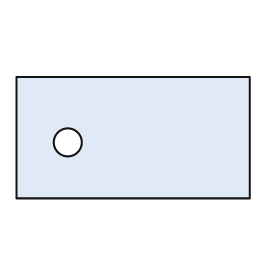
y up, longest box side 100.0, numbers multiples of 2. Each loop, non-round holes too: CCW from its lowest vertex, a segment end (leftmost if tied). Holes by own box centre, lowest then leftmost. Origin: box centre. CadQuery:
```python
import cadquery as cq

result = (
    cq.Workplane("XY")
    .moveTo(-50.0, -26.0)
    .lineTo(50.0, -26.0)
    .lineTo(50.0, 26.0)
    .lineTo(-50.0, 26.0)
    .close()
    .moveTo(-28.0, -2.0)
    .circle(6.0)
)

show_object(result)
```